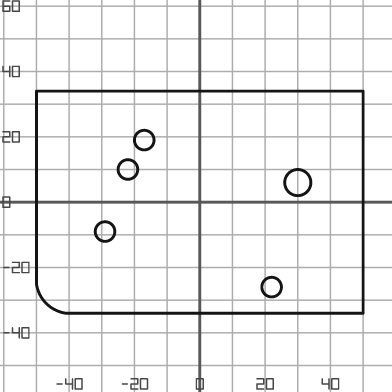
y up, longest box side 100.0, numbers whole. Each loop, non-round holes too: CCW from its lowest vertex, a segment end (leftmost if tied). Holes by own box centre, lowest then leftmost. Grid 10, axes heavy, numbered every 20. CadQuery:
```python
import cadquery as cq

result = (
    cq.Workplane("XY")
    .moveTo(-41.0, -34.0)
    .lineTo(50.0, -34.0)
    .lineTo(50.0, 34.0)
    .lineTo(-50.0, 34.0)
    .lineTo(-50.0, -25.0)
    .threePointArc((-47.0, -31.0), (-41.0, -34.0))
    .close()
    .moveTo(22.0, -26.0)
    .circle(3.0)
    .moveTo(-29.0, -9.0)
    .circle(3.0)
    .moveTo(30.0, 6.0)
    .circle(4.0)
    .moveTo(-22.0, 10.0)
    .circle(3.0)
    .moveTo(-17.0, 19.0)
    .circle(3.0)
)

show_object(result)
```